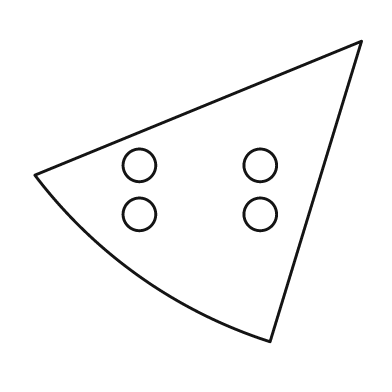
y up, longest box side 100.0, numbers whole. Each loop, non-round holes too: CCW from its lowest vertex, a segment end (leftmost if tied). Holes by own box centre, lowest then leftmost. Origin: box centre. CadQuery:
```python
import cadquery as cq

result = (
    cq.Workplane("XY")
    .moveTo(22.0, -46.0)
    .lineTo(50.0, 46.0)
    .lineTo(-50.0, 5.0)
    .threePointArc((-18.0, -26.0), (22.0, -46.0))
    .close()
    .moveTo(-18.0, -7.0)
    .circle(5.0)
    .moveTo(19.0, -7.0)
    .circle(5.0)
    .moveTo(-18.0, 8.0)
    .circle(5.0)
    .moveTo(19.0, 8.0)
    .circle(5.0)
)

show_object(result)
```